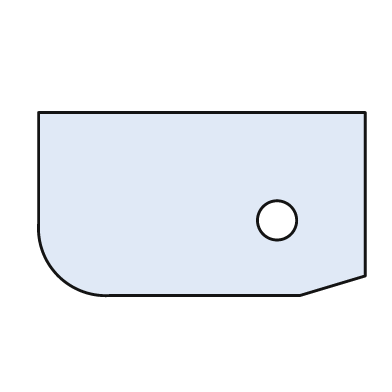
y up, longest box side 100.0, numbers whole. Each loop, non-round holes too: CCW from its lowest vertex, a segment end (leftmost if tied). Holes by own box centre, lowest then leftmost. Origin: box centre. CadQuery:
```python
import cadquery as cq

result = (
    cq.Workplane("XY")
    .moveTo(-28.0, -28.0)
    .lineTo(30.0, -28.0)
    .lineTo(50.0, -22.0)
    .lineTo(50.0, 28.0)
    .lineTo(-50.0, 28.0)
    .lineTo(-50.0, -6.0)
    .threePointArc((-44.0, -22.0), (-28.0, -28.0))
    .close()
    .moveTo(23.0, -5.0)
    .circle(6.0)
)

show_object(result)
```